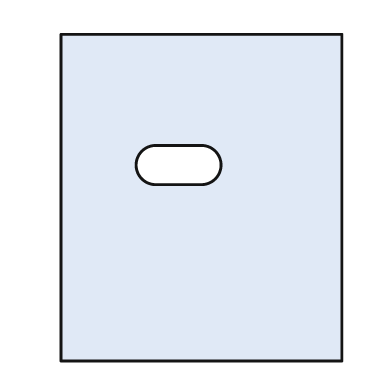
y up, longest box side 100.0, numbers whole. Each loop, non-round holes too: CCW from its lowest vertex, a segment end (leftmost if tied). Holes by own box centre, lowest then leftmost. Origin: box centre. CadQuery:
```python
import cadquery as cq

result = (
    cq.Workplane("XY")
    .moveTo(-43.0, -50.0)
    .lineTo(43.0, -50.0)
    .lineTo(43.0, 50.0)
    .lineTo(-43.0, 50.0)
    .close()
    .moveTo(-14.0, 4.0)
    .lineTo(0.0, 4.0)
    .threePointArc((6.0, 10.0), (0.0, 16.0))
    .lineTo(-14.0, 16.0)
    .threePointArc((-20.0, 10.0), (-14.0, 4.0))
    .close()
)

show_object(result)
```